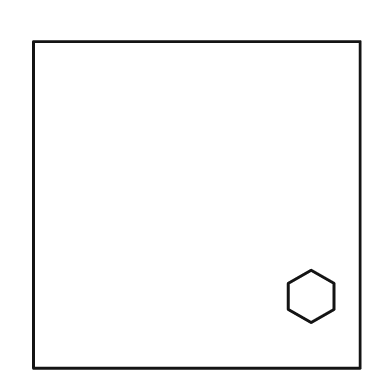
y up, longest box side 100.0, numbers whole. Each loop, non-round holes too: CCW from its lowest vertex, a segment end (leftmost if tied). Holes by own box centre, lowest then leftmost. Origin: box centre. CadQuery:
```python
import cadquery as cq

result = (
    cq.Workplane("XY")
    .moveTo(-50.0, -50.0)
    .lineTo(50.0, -50.0)
    .lineTo(50.0, 50.0)
    .lineTo(-50.0, 50.0)
    .close()
    .moveTo(35.0, -36.0)
    .lineTo(42.0, -32.0)
    .lineTo(42.0, -24.0)
    .lineTo(35.0, -20.0)
    .lineTo(28.0, -24.0)
    .lineTo(28.0, -32.0)
    .close()
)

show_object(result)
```